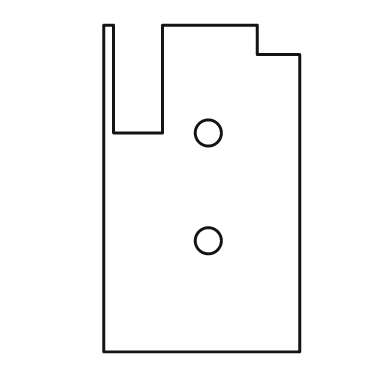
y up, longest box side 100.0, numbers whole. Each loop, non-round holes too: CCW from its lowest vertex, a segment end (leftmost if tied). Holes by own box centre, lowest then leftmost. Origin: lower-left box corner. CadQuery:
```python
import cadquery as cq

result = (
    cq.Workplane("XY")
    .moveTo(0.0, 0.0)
    .lineTo(60.0, 0.0)
    .lineTo(60.0, 91.0)
    .lineTo(47.0, 91.0)
    .lineTo(47.0, 100.0)
    .lineTo(18.0, 100.0)
    .lineTo(18.0, 67.0)
    .lineTo(3.0, 67.0)
    .lineTo(3.0, 100.0)
    .lineTo(0.0, 100.0)
    .close()
    .moveTo(32.0, 34.0)
    .circle(4.0)
    .moveTo(32.0, 67.0)
    .circle(4.0)
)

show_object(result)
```